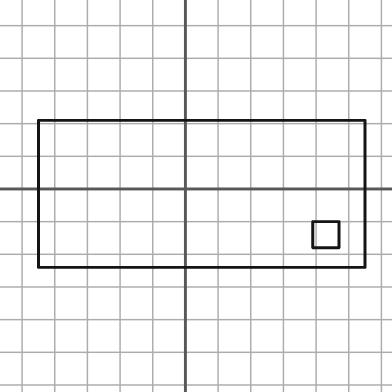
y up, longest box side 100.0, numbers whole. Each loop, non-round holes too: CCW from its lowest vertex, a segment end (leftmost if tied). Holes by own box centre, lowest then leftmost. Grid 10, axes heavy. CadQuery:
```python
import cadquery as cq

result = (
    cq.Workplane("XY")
    .moveTo(-45.0, -24.0)
    .lineTo(55.0, -24.0)
    .lineTo(55.0, 21.0)
    .lineTo(-45.0, 21.0)
    .close()
    .moveTo(39.0, -18.0)
    .lineTo(47.0, -18.0)
    .lineTo(47.0, -10.0)
    .lineTo(39.0, -10.0)
    .close()
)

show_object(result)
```